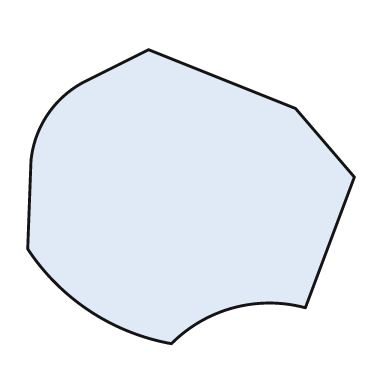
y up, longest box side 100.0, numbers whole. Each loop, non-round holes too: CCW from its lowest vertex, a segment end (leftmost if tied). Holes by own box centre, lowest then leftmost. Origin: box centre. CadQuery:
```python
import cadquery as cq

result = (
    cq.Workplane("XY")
    .moveTo(-6.0, -45.0)
    .threePointArc((13.0, -34.0), (35.0, -34.0))
    .lineTo(50.0, 6.0)
    .lineTo(32.0, 27.0)
    .lineTo(-13.0, 45.0)
    .lineTo(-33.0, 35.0)
    .threePointArc((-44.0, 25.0), (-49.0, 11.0))
    .lineTo(-50.0, -16.0)
    .threePointArc((-31.0, -35.0), (-6.0, -45.0))
    .close()
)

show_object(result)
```